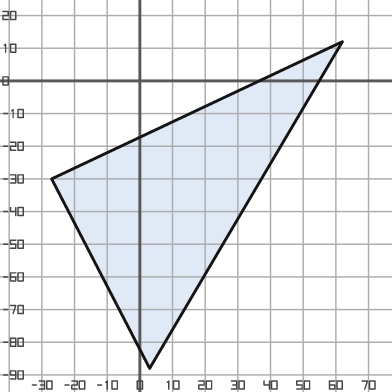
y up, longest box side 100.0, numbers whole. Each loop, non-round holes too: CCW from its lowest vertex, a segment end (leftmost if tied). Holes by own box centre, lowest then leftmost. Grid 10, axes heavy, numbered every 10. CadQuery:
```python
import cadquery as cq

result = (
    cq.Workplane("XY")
    .moveTo(3.0, -88.0)
    .lineTo(62.0, 12.0)
    .lineTo(-27.0, -30.0)
    .close()
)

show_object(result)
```